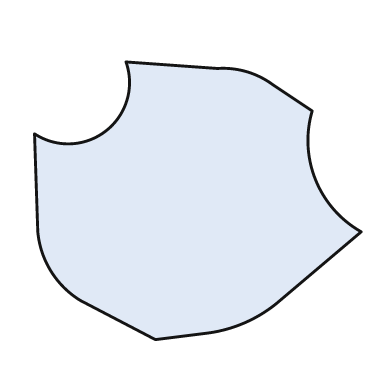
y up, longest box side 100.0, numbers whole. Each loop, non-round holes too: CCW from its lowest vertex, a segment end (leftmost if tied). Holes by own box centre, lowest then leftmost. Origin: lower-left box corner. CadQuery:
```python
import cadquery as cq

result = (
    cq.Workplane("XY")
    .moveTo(37.0, 0.0)
    .lineTo(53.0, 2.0)
    .threePointArc((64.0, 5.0), (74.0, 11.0))
    .lineTo(100.0, 33.0)
    .threePointArc((86.0, 49.0), (85.0, 70.0))
    .lineTo(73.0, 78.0)
    .threePointArc((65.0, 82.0), (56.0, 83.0))
    .lineTo(28.0, 85.0)
    .threePointArc((22.0, 64.0), (0.0, 63.0))
    .lineTo(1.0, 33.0)
    .threePointArc((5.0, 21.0), (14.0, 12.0))
    .close()
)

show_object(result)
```